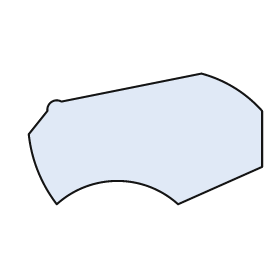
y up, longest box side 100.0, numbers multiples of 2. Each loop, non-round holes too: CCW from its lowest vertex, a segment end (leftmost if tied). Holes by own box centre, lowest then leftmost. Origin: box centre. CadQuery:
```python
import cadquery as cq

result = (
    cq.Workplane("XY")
    .moveTo(-38.0, -28.0)
    .threePointArc((-12.0, -18.0), (14.0, -28.0))
    .lineTo(50.0, -12.0)
    .lineTo(50.0, 12.0)
    .threePointArc((38.0, 22.0), (24.0, 28.0))
    .lineTo(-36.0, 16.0)
    .threePointArc((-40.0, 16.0), (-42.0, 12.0))
    .lineTo(-50.0, 2.0)
    .threePointArc((-46.0, -14.0), (-38.0, -28.0))
    .close()
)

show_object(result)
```